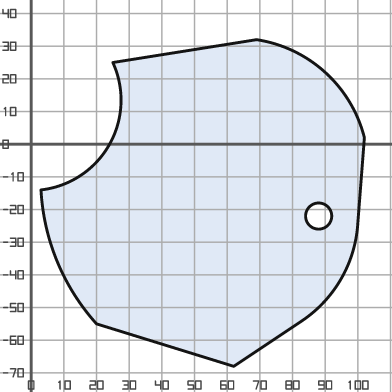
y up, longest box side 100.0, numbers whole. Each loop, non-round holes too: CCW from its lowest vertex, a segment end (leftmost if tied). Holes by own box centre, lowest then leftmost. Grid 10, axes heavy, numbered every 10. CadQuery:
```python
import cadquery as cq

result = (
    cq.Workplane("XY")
    .moveTo(62.0, -68.0)
    .lineTo(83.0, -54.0)
    .threePointArc((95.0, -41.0), (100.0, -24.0))
    .lineTo(102.0, 2.0)
    .threePointArc((90.0, 22.0), (69.0, 32.0))
    .lineTo(25.0, 25.0)
    .threePointArc((24.0, 0.0), (3.0, -14.0))
    .threePointArc((8.0, -36.0), (20.0, -55.0))
    .close()
    .moveTo(88.0, -22.0)
    .circle(4.0)
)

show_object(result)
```